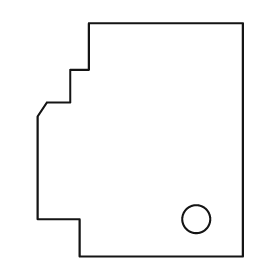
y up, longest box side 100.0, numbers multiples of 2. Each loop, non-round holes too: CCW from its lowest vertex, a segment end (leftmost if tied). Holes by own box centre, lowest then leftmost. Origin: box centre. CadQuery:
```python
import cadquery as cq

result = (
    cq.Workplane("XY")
    .moveTo(-26.0, -50.0)
    .lineTo(44.0, -50.0)
    .lineTo(44.0, 50.0)
    .lineTo(-22.0, 50.0)
    .lineTo(-22.0, 30.0)
    .lineTo(-30.0, 30.0)
    .lineTo(-30.0, 16.0)
    .lineTo(-40.0, 16.0)
    .lineTo(-44.0, 10.0)
    .lineTo(-44.0, -34.0)
    .lineTo(-26.0, -34.0)
    .close()
    .moveTo(24.0, -34.0)
    .circle(6.0)
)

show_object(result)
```